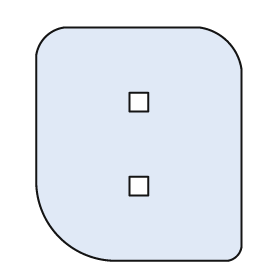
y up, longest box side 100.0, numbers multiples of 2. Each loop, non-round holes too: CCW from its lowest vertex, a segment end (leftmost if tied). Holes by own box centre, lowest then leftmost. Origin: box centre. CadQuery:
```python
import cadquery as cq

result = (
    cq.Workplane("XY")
    .moveTo(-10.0, -50.0)
    .lineTo(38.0, -50.0)
    .threePointArc((42.0, -48.0), (44.0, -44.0))
    .lineTo(44.0, 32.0)
    .threePointArc((38.0, 44.0), (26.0, 50.0))
    .lineTo(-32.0, 50.0)
    .threePointArc((-40.0, 46.0), (-44.0, 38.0))
    .lineTo(-44.0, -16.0)
    .threePointArc((-34.0, -40.0), (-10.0, -50.0))
    .close()
    .moveTo(-4.0, -22.0)
    .lineTo(4.0, -22.0)
    .lineTo(4.0, -14.0)
    .lineTo(-4.0, -14.0)
    .close()
    .moveTo(-4.0, 14.0)
    .lineTo(4.0, 14.0)
    .lineTo(4.0, 22.0)
    .lineTo(-4.0, 22.0)
    .close()
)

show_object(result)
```